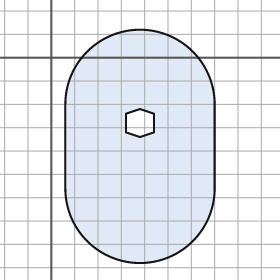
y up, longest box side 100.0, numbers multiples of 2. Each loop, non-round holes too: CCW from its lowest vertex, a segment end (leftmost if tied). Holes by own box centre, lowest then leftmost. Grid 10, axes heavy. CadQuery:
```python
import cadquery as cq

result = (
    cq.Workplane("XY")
    .moveTo(6.0, -56.0)
    .threePointArc((38.0, -88.0), (70.0, -56.0))
    .lineTo(70.0, -20.0)
    .threePointArc((38.0, 12.0), (6.0, -20.0))
    .close()
    .moveTo(38.0, -34.0)
    .lineTo(44.0, -32.0)
    .lineTo(44.0, -24.0)
    .lineTo(38.0, -22.0)
    .lineTo(32.0, -24.0)
    .lineTo(32.0, -32.0)
    .close()
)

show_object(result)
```